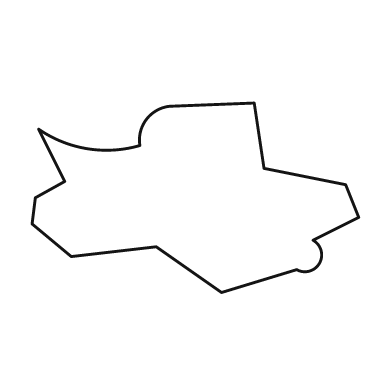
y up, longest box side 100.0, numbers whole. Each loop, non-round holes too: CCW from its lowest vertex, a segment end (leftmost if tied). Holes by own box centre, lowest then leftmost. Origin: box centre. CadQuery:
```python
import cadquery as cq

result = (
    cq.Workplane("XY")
    .moveTo(8.0, -29.0)
    .lineTo(31.0, -22.0)
    .threePointArc((38.0, -20.0), (36.0, -13.0))
    .lineTo(50.0, -6.0)
    .lineTo(46.0, 4.0)
    .lineTo(21.0, 9.0)
    .lineTo(18.0, 29.0)
    .lineTo(-8.0, 28.0)
    .threePointArc((-15.0, 24.0), (-17.0, 16.0))
    .threePointArc((-33.0, 15.0), (-48.0, 21.0))
    .lineTo(-40.0, 5.0)
    .lineTo(-49.0, 0.0)
    .lineTo(-50.0, -8.0)
    .lineTo(-38.0, -18.0)
    .lineTo(-12.0, -15.0)
    .close()
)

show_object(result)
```